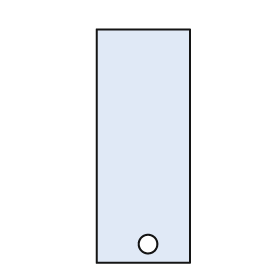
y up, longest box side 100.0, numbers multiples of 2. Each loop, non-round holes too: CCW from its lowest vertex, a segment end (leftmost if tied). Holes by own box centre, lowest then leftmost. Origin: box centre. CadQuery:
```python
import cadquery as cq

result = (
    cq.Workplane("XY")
    .moveTo(-20.0, -50.0)
    .lineTo(20.0, -50.0)
    .lineTo(20.0, 50.0)
    .lineTo(-20.0, 50.0)
    .close()
    .moveTo(2.0, -42.0)
    .circle(4.0)
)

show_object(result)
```